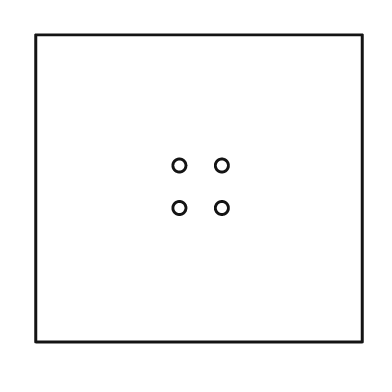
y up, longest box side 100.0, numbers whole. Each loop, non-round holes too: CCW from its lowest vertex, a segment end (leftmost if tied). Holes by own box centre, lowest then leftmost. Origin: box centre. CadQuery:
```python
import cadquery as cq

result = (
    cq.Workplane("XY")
    .moveTo(-50.0, -47.0)
    .lineTo(50.0, -47.0)
    .lineTo(50.0, 47.0)
    .lineTo(-50.0, 47.0)
    .close()
    .moveTo(-6.0, -6.0)
    .circle(2.0)
    .moveTo(7.0, -6.0)
    .circle(2.0)
    .moveTo(-6.0, 7.0)
    .circle(2.0)
    .moveTo(7.0, 7.0)
    .circle(2.0)
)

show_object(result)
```